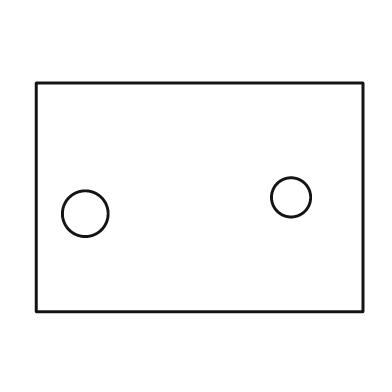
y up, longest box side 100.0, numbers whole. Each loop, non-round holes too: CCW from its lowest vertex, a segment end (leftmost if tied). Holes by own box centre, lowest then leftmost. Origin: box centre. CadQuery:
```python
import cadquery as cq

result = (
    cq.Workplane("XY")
    .moveTo(-50.0, -35.0)
    .lineTo(50.0, -35.0)
    .lineTo(50.0, 35.0)
    .lineTo(-50.0, 35.0)
    .close()
    .moveTo(-35.0, -5.0)
    .circle(7.0)
    .moveTo(28.0, 0.0)
    .circle(6.0)
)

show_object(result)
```